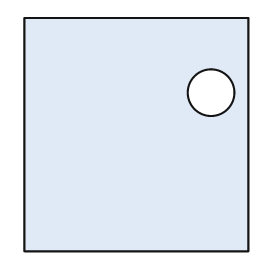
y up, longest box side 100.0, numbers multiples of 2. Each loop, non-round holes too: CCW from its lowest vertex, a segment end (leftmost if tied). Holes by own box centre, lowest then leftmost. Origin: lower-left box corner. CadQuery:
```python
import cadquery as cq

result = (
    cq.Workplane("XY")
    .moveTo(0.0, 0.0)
    .lineTo(96.0, 0.0)
    .lineTo(96.0, 100.0)
    .lineTo(0.0, 100.0)
    .close()
    .moveTo(80.0, 68.0)
    .circle(10.0)
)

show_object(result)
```